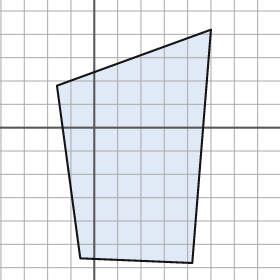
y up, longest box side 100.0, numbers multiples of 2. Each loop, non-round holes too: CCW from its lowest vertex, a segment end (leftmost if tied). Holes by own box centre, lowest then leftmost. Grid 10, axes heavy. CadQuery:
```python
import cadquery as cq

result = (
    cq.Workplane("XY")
    .moveTo(42.0, -58.0)
    .lineTo(50.0, 42.0)
    .lineTo(-16.0, 18.0)
    .lineTo(-6.0, -56.0)
    .close()
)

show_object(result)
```